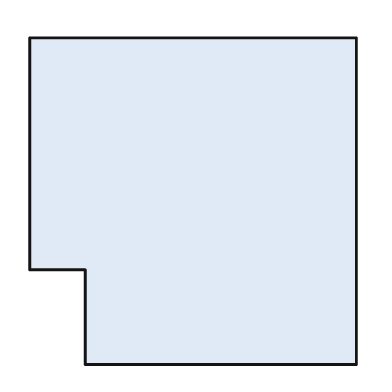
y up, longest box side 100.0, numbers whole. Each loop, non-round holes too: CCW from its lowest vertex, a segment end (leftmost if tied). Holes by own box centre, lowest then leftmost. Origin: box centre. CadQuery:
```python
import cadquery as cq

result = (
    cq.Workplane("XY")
    .moveTo(-33.0, -50.0)
    .lineTo(50.0, -50.0)
    .lineTo(50.0, 50.0)
    .lineTo(-50.0, 50.0)
    .lineTo(-50.0, -21.0)
    .lineTo(-33.0, -21.0)
    .close()
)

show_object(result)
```